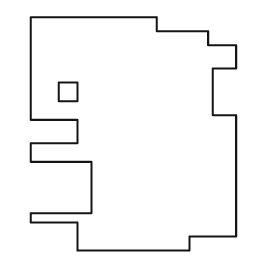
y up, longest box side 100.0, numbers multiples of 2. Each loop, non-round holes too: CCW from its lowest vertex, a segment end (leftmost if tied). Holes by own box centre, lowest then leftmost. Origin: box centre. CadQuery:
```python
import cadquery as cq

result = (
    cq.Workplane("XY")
    .moveTo(-24.0, -50.0)
    .lineTo(24.0, -50.0)
    .lineTo(24.0, -44.0)
    .lineTo(44.0, -44.0)
    .lineTo(44.0, 8.0)
    .lineTo(34.0, 8.0)
    .lineTo(34.0, 28.0)
    .lineTo(44.0, 28.0)
    .lineTo(44.0, 38.0)
    .lineTo(32.0, 38.0)
    .lineTo(32.0, 44.0)
    .lineTo(10.0, 44.0)
    .lineTo(10.0, 50.0)
    .lineTo(-44.0, 50.0)
    .lineTo(-44.0, 6.0)
    .lineTo(-24.0, 6.0)
    .lineTo(-24.0, -4.0)
    .lineTo(-44.0, -4.0)
    .lineTo(-44.0, -12.0)
    .lineTo(-18.0, -12.0)
    .lineTo(-18.0, -34.0)
    .lineTo(-44.0, -34.0)
    .lineTo(-44.0, -38.0)
    .lineTo(-24.0, -38.0)
    .close()
    .moveTo(-32.0, 14.0)
    .lineTo(-24.0, 14.0)
    .lineTo(-24.0, 22.0)
    .lineTo(-32.0, 22.0)
    .close()
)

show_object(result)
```